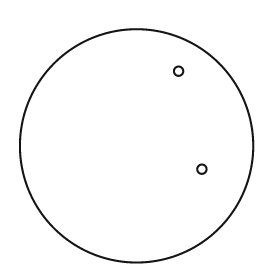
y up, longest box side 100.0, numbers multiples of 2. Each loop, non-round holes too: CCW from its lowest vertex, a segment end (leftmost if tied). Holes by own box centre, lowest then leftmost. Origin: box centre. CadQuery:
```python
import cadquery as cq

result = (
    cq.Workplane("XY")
    .moveTo(0.0, 0.0)
    .circle(50.0)
    .moveTo(28.0, -10.0)
    .circle(2.0)
    .moveTo(18.0, 32.0)
    .circle(2.0)
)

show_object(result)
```